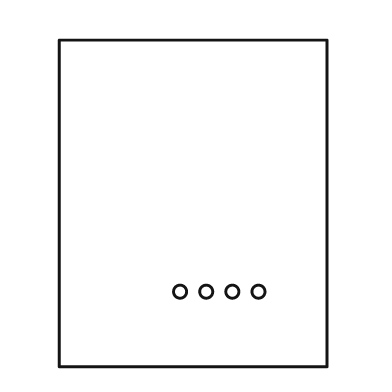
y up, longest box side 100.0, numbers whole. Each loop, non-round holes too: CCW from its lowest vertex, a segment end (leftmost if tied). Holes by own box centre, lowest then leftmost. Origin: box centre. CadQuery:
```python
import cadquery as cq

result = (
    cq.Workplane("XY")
    .moveTo(-41.0, -50.0)
    .lineTo(41.0, -50.0)
    .lineTo(41.0, 50.0)
    .lineTo(-41.0, 50.0)
    .close()
    .moveTo(-4.0, -27.0)
    .circle(2.0)
    .moveTo(4.0, -27.0)
    .circle(2.0)
    .moveTo(12.0, -27.0)
    .circle(2.0)
    .moveTo(20.0, -27.0)
    .circle(2.0)
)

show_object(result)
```